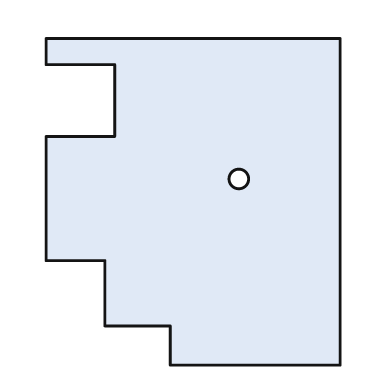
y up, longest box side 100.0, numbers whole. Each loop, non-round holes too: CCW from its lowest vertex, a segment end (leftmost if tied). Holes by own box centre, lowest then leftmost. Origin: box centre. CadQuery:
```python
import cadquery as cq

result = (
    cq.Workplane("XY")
    .moveTo(-7.0, -50.0)
    .lineTo(45.0, -50.0)
    .lineTo(45.0, 50.0)
    .lineTo(-45.0, 50.0)
    .lineTo(-45.0, 42.0)
    .lineTo(-24.0, 42.0)
    .lineTo(-24.0, 20.0)
    .lineTo(-45.0, 20.0)
    .lineTo(-45.0, -18.0)
    .lineTo(-27.0, -18.0)
    .lineTo(-27.0, -38.0)
    .lineTo(-7.0, -38.0)
    .close()
    .moveTo(14.0, 7.0)
    .circle(3.0)
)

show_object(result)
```